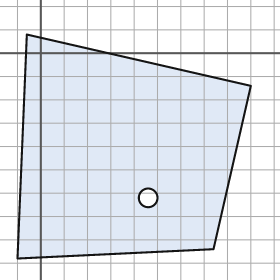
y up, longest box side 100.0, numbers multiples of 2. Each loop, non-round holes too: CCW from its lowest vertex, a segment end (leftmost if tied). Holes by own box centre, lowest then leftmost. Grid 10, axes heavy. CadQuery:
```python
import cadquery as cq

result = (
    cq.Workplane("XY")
    .moveTo(-10.0, -88.0)
    .lineTo(74.0, -84.0)
    .lineTo(90.0, -14.0)
    .lineTo(-6.0, 8.0)
    .close()
    .moveTo(46.0, -62.0)
    .circle(4.0)
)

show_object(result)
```